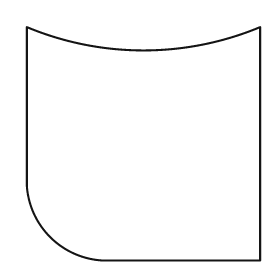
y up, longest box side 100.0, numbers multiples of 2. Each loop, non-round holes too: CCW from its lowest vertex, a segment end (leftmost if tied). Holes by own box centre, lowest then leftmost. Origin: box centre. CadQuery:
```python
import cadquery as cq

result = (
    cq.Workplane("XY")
    .moveTo(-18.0, -50.0)
    .lineTo(50.0, -50.0)
    .lineTo(50.0, 50.0)
    .threePointArc((0.0, 40.0), (-50.0, 50.0))
    .lineTo(-50.0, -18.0)
    .threePointArc((-40.0, -40.0), (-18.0, -50.0))
    .close()
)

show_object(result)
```